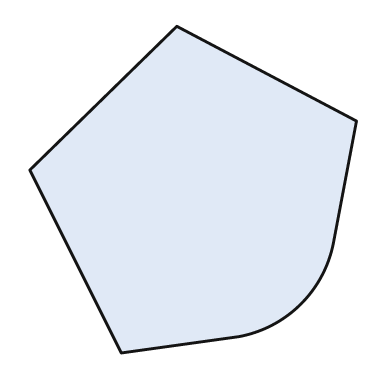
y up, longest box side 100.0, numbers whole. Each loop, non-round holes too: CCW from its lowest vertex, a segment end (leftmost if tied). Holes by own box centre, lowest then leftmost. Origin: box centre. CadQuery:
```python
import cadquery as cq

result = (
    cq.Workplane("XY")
    .moveTo(-22.0, -50.0)
    .lineTo(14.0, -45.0)
    .threePointArc((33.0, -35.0), (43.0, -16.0))
    .lineTo(50.0, 21.0)
    .lineTo(-5.0, 50.0)
    .lineTo(-50.0, 6.0)
    .close()
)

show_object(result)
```